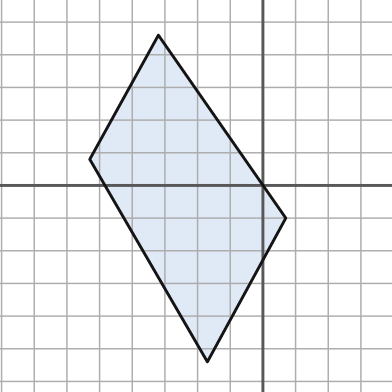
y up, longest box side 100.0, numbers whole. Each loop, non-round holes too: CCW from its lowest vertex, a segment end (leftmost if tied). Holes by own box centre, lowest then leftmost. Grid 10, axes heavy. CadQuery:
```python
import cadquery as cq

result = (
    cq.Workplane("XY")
    .moveTo(-17.0, -54.0)
    .lineTo(7.0, -10.0)
    .lineTo(-32.0, 46.0)
    .lineTo(-53.0, 8.0)
    .close()
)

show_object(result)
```